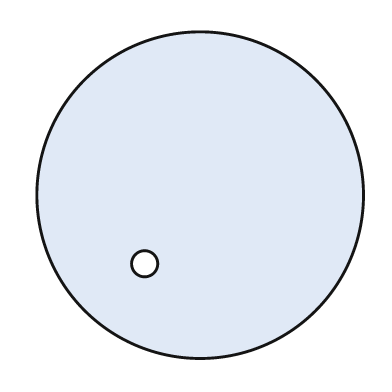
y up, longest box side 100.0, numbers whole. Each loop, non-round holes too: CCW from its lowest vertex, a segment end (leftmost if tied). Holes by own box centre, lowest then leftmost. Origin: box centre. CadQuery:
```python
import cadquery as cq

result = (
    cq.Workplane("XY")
    .moveTo(0.0, 0.0)
    .circle(50.0)
    .moveTo(-17.0, -21.0)
    .circle(4.0)
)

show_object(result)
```